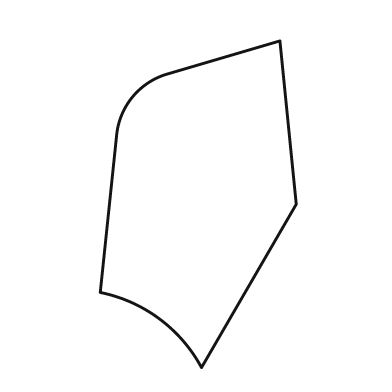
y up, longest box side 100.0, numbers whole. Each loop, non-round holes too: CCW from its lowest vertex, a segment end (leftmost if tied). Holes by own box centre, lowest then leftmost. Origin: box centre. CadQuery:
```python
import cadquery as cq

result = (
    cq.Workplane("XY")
    .moveTo(1.0, -50.0)
    .lineTo(30.0, 0.0)
    .lineTo(25.0, 50.0)
    .lineTo(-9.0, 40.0)
    .threePointArc((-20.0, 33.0), (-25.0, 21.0))
    .lineTo(-30.0, -27.0)
    .threePointArc((-12.0, -35.0), (1.0, -50.0))
    .close()
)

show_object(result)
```